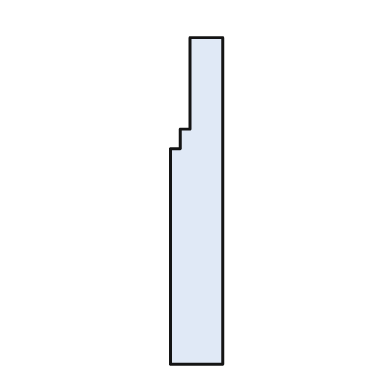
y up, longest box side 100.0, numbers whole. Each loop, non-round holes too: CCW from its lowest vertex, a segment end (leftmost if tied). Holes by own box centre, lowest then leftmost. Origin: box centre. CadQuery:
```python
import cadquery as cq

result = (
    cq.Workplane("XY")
    .moveTo(-8.0, -50.0)
    .lineTo(8.0, -50.0)
    .lineTo(8.0, 50.0)
    .lineTo(-2.0, 50.0)
    .lineTo(-2.0, 22.0)
    .lineTo(-5.0, 22.0)
    .lineTo(-5.0, 16.0)
    .lineTo(-8.0, 16.0)
    .close()
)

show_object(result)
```